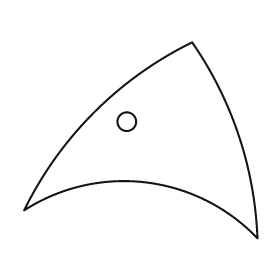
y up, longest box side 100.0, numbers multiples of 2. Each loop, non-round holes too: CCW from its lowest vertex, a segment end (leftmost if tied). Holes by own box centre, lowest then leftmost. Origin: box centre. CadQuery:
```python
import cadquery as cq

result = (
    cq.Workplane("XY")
    .moveTo(50.0, -42.0)
    .threePointArc((42.0, 2.0), (22.0, 42.0))
    .threePointArc((-20.0, 12.0), (-50.0, -30.0))
    .threePointArc((2.0, -18.0), (50.0, -42.0))
    .close()
    .moveTo(-6.0, 8.0)
    .circle(4.0)
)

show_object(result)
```